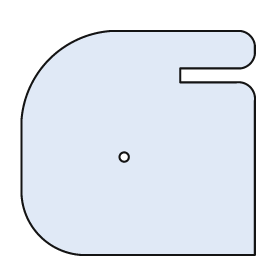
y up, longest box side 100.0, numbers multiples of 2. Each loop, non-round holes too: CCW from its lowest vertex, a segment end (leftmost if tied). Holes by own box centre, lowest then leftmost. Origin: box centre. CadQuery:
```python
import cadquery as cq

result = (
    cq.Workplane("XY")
    .moveTo(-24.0, -48.0)
    .lineTo(50.0, -48.0)
    .lineTo(50.0, 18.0)
    .threePointArc((48.0, 24.0), (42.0, 26.0))
    .lineTo(18.0, 26.0)
    .lineTo(18.0, 32.0)
    .lineTo(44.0, 32.0)
    .threePointArc((48.0, 34.0), (50.0, 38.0))
    .lineTo(50.0, 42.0)
    .threePointArc((48.0, 46.0), (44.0, 48.0))
    .lineTo(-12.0, 48.0)
    .threePointArc((-38.0, 36.0), (-50.0, 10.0))
    .lineTo(-50.0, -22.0)
    .threePointArc((-42.0, -40.0), (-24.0, -48.0))
    .close()
    .moveTo(-6.0, -6.0)
    .circle(2.0)
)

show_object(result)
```